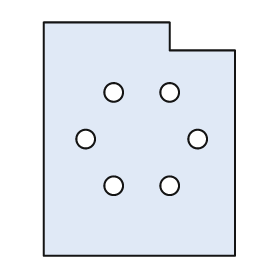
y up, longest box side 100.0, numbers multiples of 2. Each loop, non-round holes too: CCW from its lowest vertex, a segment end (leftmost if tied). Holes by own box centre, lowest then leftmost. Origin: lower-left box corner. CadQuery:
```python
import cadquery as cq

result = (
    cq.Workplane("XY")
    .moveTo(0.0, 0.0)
    .lineTo(82.0, 0.0)
    .lineTo(82.0, 88.0)
    .lineTo(54.0, 88.0)
    .lineTo(54.0, 100.0)
    .lineTo(0.0, 100.0)
    .close()
    .moveTo(30.0, 30.0)
    .circle(4.0)
    .moveTo(54.0, 30.0)
    .circle(4.0)
    .moveTo(18.0, 50.0)
    .circle(4.0)
    .moveTo(66.0, 50.0)
    .circle(4.0)
    .moveTo(30.0, 70.0)
    .circle(4.0)
    .moveTo(54.0, 70.0)
    .circle(4.0)
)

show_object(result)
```